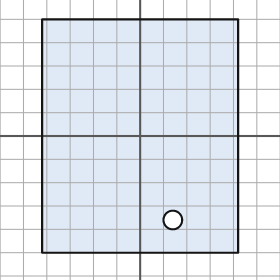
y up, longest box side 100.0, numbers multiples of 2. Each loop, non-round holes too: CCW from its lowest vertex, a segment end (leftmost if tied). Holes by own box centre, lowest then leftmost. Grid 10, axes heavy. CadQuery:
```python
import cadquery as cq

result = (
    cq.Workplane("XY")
    .moveTo(-42.0, -50.0)
    .lineTo(42.0, -50.0)
    .lineTo(42.0, 50.0)
    .lineTo(-42.0, 50.0)
    .close()
    .moveTo(14.0, -36.0)
    .circle(4.0)
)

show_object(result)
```